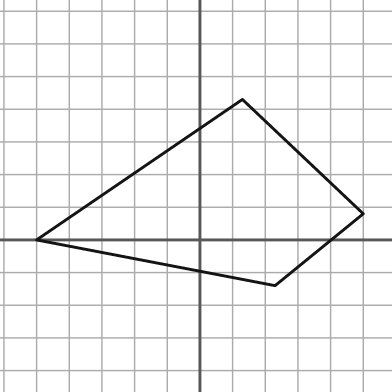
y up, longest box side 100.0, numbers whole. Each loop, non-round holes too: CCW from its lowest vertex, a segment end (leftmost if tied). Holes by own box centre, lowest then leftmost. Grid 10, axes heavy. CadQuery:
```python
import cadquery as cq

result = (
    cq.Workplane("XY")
    .moveTo(23.0, -14.0)
    .lineTo(50.0, 8.0)
    .lineTo(13.0, 43.0)
    .lineTo(-50.0, 0.0)
    .close()
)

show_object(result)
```